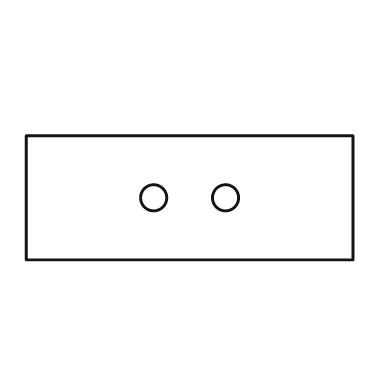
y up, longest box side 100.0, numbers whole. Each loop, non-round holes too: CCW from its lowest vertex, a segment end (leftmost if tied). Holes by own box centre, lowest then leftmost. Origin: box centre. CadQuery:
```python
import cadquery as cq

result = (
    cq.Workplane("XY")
    .moveTo(-50.0, -19.0)
    .lineTo(50.0, -19.0)
    .lineTo(50.0, 19.0)
    .lineTo(-50.0, 19.0)
    .close()
    .moveTo(-11.0, 0.0)
    .circle(4.0)
    .moveTo(11.0, 0.0)
    .circle(4.0)
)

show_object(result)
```